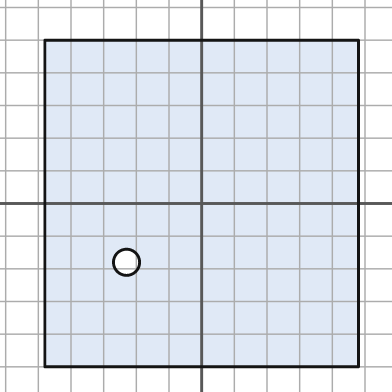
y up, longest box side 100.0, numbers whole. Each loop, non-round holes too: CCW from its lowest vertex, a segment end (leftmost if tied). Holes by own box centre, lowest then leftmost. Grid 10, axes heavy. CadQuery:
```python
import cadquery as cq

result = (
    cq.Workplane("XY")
    .moveTo(-48.0, -50.0)
    .lineTo(48.0, -50.0)
    .lineTo(48.0, 50.0)
    .lineTo(-48.0, 50.0)
    .close()
    .moveTo(-23.0, -18.0)
    .circle(4.0)
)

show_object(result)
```